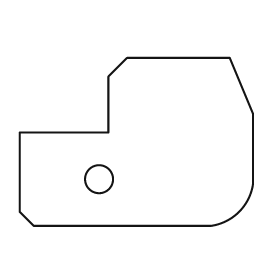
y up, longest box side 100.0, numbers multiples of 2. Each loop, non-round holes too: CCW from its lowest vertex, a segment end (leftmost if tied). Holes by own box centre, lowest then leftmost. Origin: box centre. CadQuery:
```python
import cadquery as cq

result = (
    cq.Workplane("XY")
    .moveTo(-44.0, -36.0)
    .lineTo(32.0, -36.0)
    .threePointArc((44.0, -30.0), (50.0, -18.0))
    .lineTo(50.0, 12.0)
    .lineTo(40.0, 36.0)
    .lineTo(-4.0, 36.0)
    .lineTo(-12.0, 28.0)
    .lineTo(-12.0, 4.0)
    .lineTo(-50.0, 4.0)
    .lineTo(-50.0, -30.0)
    .close()
    .moveTo(-16.0, -16.0)
    .circle(6.0)
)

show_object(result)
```